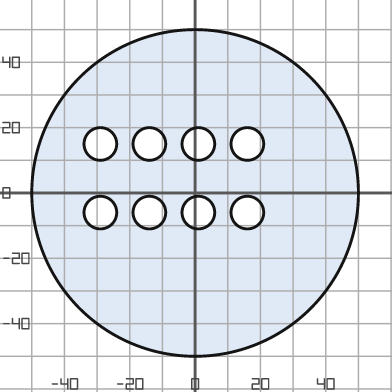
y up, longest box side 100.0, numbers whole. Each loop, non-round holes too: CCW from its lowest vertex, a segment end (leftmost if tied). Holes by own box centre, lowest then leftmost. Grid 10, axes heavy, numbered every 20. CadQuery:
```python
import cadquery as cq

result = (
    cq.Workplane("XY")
    .moveTo(0.0, 0.0)
    .circle(50.0)
    .moveTo(-29.0, -6.0)
    .circle(5.0)
    .moveTo(-14.0, -6.0)
    .circle(5.0)
    .moveTo(1.0, -6.0)
    .circle(5.0)
    .moveTo(16.0, -6.0)
    .circle(5.0)
    .moveTo(-29.0, 15.0)
    .circle(5.0)
    .moveTo(-14.0, 15.0)
    .circle(5.0)
    .moveTo(1.0, 15.0)
    .circle(5.0)
    .moveTo(16.0, 15.0)
    .circle(5.0)
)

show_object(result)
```